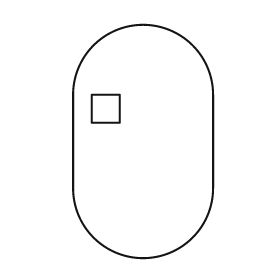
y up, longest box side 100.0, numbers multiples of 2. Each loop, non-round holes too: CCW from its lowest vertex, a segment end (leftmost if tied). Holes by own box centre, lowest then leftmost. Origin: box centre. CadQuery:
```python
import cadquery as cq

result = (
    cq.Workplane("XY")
    .moveTo(-30.0, -20.0)
    .threePointArc((0.0, -50.0), (30.0, -20.0))
    .lineTo(30.0, 20.0)
    .threePointArc((0.0, 50.0), (-30.0, 20.0))
    .close()
    .moveTo(-22.0, 8.0)
    .lineTo(-10.0, 8.0)
    .lineTo(-10.0, 20.0)
    .lineTo(-22.0, 20.0)
    .close()
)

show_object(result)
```